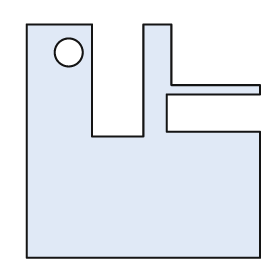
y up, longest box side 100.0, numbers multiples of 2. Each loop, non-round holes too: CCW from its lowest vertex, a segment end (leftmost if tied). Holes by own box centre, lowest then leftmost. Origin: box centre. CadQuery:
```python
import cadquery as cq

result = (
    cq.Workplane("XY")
    .moveTo(-50.0, -50.0)
    .lineTo(50.0, -50.0)
    .lineTo(50.0, 4.0)
    .lineTo(10.0, 4.0)
    .lineTo(10.0, 20.0)
    .lineTo(50.0, 20.0)
    .lineTo(50.0, 24.0)
    .lineTo(12.0, 24.0)
    .lineTo(12.0, 50.0)
    .lineTo(0.0, 50.0)
    .lineTo(0.0, 2.0)
    .lineTo(-22.0, 2.0)
    .lineTo(-22.0, 50.0)
    .lineTo(-50.0, 50.0)
    .close()
    .moveTo(-32.0, 38.0)
    .circle(6.0)
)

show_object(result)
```